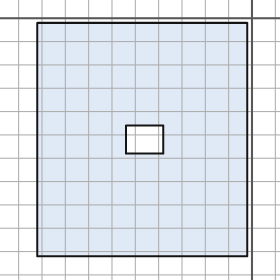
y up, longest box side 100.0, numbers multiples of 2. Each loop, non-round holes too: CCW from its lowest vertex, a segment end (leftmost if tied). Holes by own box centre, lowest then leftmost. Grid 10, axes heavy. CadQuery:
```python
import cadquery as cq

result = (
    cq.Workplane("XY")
    .moveTo(-92.0, -102.0)
    .lineTo(-2.0, -102.0)
    .lineTo(-2.0, -2.0)
    .lineTo(-92.0, -2.0)
    .close()
    .moveTo(-54.0, -58.0)
    .lineTo(-38.0, -58.0)
    .lineTo(-38.0, -46.0)
    .lineTo(-54.0, -46.0)
    .close()
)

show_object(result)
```